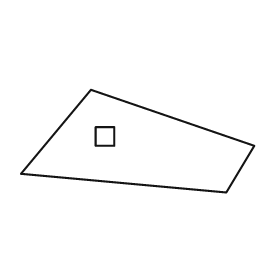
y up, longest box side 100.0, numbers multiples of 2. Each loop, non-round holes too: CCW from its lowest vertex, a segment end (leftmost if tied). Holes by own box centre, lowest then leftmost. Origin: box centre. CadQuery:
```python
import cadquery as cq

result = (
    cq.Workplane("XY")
    .moveTo(38.0, -22.0)
    .lineTo(50.0, -2.0)
    .lineTo(-20.0, 22.0)
    .lineTo(-50.0, -14.0)
    .close()
    .moveTo(-18.0, -2.0)
    .lineTo(-10.0, -2.0)
    .lineTo(-10.0, 6.0)
    .lineTo(-18.0, 6.0)
    .close()
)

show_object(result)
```